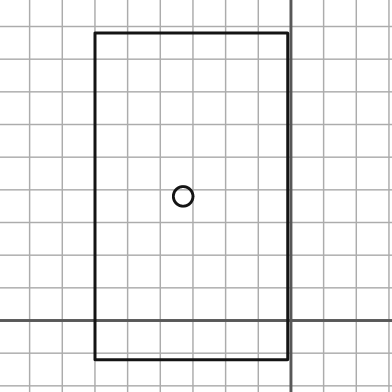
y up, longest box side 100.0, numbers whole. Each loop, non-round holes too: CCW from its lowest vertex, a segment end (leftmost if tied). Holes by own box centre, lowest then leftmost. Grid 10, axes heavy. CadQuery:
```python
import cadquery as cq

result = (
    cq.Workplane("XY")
    .moveTo(-60.0, -12.0)
    .lineTo(-1.0, -12.0)
    .lineTo(-1.0, 88.0)
    .lineTo(-60.0, 88.0)
    .close()
    .moveTo(-33.0, 38.0)
    .circle(3.0)
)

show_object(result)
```